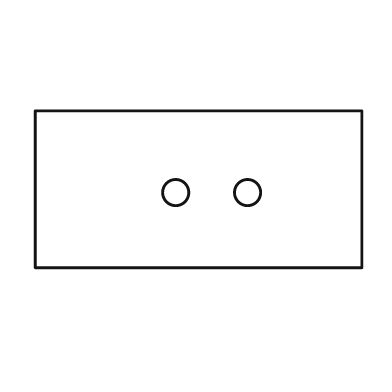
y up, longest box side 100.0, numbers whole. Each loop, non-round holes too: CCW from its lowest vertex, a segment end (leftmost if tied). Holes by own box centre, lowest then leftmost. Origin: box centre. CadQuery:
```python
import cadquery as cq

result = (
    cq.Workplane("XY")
    .moveTo(-50.0, -24.0)
    .lineTo(50.0, -24.0)
    .lineTo(50.0, 24.0)
    .lineTo(-50.0, 24.0)
    .close()
    .moveTo(-7.0, -1.0)
    .circle(4.0)
    .moveTo(15.0, -1.0)
    .circle(4.0)
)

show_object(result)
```